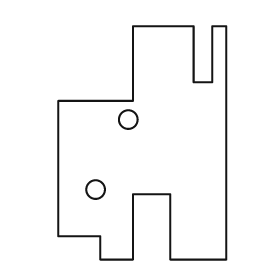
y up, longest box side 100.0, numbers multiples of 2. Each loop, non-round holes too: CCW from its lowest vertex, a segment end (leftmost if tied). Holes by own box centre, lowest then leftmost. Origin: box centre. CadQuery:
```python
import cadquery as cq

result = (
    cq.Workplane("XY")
    .moveTo(-18.0, -50.0)
    .lineTo(-4.0, -50.0)
    .lineTo(-4.0, -22.0)
    .lineTo(12.0, -22.0)
    .lineTo(12.0, -50.0)
    .lineTo(36.0, -50.0)
    .lineTo(36.0, 50.0)
    .lineTo(30.0, 50.0)
    .lineTo(30.0, 26.0)
    .lineTo(22.0, 26.0)
    .lineTo(22.0, 50.0)
    .lineTo(-4.0, 50.0)
    .lineTo(-4.0, 18.0)
    .lineTo(-36.0, 18.0)
    .lineTo(-36.0, -40.0)
    .lineTo(-18.0, -40.0)
    .close()
    .moveTo(-20.0, -20.0)
    .circle(4.0)
    .moveTo(-6.0, 10.0)
    .circle(4.0)
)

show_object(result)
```